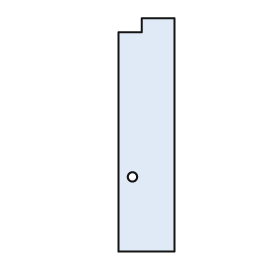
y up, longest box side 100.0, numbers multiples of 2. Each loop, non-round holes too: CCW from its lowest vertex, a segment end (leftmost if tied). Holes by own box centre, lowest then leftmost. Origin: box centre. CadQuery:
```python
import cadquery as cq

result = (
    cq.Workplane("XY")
    .moveTo(-12.0, -50.0)
    .lineTo(12.0, -50.0)
    .lineTo(12.0, 50.0)
    .lineTo(-2.0, 50.0)
    .lineTo(-2.0, 44.0)
    .lineTo(-12.0, 44.0)
    .close()
    .moveTo(-6.0, -18.0)
    .circle(2.0)
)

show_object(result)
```